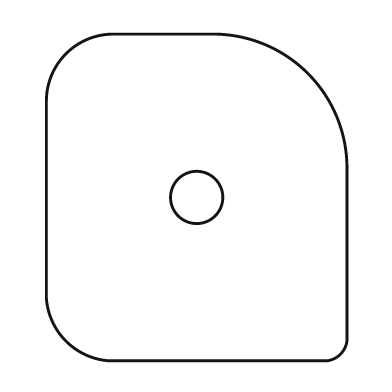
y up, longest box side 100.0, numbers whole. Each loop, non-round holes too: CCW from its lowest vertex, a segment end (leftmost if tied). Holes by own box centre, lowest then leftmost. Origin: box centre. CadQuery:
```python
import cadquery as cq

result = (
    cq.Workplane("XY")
    .moveTo(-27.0, -50.0)
    .lineTo(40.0, -50.0)
    .threePointArc((44.0, -48.0), (46.0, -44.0))
    .lineTo(46.0, 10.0)
    .threePointArc((34.0, 38.0), (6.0, 50.0))
    .lineTo(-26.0, 50.0)
    .threePointArc((-40.0, 44.0), (-46.0, 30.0))
    .lineTo(-46.0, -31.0)
    .threePointArc((-40.0, -44.0), (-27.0, -50.0))
    .close()
    .moveTo(0.0, 0.0)
    .circle(8.0)
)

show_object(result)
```